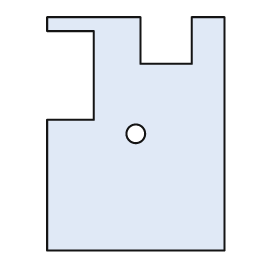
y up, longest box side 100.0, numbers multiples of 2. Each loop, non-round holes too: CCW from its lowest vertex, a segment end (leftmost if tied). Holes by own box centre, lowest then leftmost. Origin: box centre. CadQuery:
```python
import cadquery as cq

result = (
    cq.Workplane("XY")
    .moveTo(-38.0, -50.0)
    .lineTo(38.0, -50.0)
    .lineTo(38.0, 50.0)
    .lineTo(24.0, 50.0)
    .lineTo(24.0, 30.0)
    .lineTo(2.0, 30.0)
    .lineTo(2.0, 50.0)
    .lineTo(-38.0, 50.0)
    .lineTo(-38.0, 44.0)
    .lineTo(-18.0, 44.0)
    .lineTo(-18.0, 6.0)
    .lineTo(-38.0, 6.0)
    .close()
    .moveTo(0.0, 0.0)
    .circle(4.0)
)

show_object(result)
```